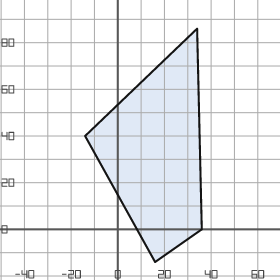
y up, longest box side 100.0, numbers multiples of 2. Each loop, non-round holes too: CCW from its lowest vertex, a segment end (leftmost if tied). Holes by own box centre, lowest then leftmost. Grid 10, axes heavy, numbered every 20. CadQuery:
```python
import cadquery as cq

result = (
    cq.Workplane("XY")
    .moveTo(16.0, -14.0)
    .lineTo(36.0, 0.0)
    .lineTo(34.0, 86.0)
    .lineTo(-14.0, 40.0)
    .close()
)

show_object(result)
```